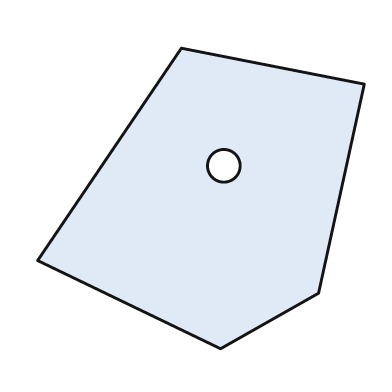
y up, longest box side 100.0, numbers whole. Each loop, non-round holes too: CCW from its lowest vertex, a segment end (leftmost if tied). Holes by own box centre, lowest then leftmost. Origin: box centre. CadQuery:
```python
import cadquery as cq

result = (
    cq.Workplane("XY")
    .moveTo(6.0, -46.0)
    .lineTo(36.0, -29.0)
    .lineTo(50.0, 35.0)
    .lineTo(-6.0, 46.0)
    .lineTo(-50.0, -19.0)
    .close()
    .moveTo(7.0, 10.0)
    .circle(5.0)
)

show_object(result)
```